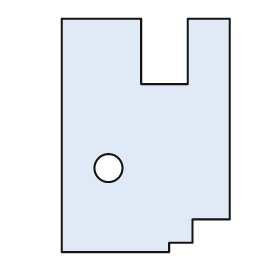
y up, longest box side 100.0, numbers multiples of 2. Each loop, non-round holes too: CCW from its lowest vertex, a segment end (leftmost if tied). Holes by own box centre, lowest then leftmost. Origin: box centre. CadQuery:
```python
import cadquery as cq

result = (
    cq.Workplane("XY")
    .moveTo(-36.0, -50.0)
    .lineTo(10.0, -50.0)
    .lineTo(10.0, -46.0)
    .lineTo(20.0, -46.0)
    .lineTo(20.0, -36.0)
    .lineTo(36.0, -36.0)
    .lineTo(36.0, 50.0)
    .lineTo(18.0, 50.0)
    .lineTo(18.0, 22.0)
    .lineTo(-2.0, 22.0)
    .lineTo(-2.0, 50.0)
    .lineTo(-36.0, 50.0)
    .close()
    .moveTo(-16.0, -14.0)
    .circle(6.0)
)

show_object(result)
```